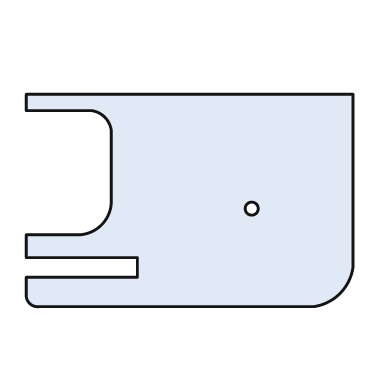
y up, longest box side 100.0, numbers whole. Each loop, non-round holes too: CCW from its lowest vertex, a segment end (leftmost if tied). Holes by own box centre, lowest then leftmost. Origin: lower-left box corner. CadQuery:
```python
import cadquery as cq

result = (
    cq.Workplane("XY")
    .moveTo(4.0, 0.0)
    .lineTo(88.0, 0.0)
    .threePointArc((96.0, 4.0), (100.0, 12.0))
    .lineTo(100.0, 65.0)
    .lineTo(0.0, 65.0)
    .lineTo(0.0, 60.0)
    .lineTo(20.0, 60.0)
    .threePointArc((24.0, 58.0), (26.0, 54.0))
    .lineTo(26.0, 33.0)
    .threePointArc((23.0, 25.0), (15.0, 22.0))
    .lineTo(0.0, 22.0)
    .lineTo(0.0, 15.0)
    .lineTo(34.0, 15.0)
    .lineTo(34.0, 9.0)
    .lineTo(0.0, 9.0)
    .lineTo(0.0, 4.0)
    .threePointArc((1.0, 1.0), (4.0, 0.0))
    .close()
    .moveTo(69.0, 30.0)
    .circle(2.0)
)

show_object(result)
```